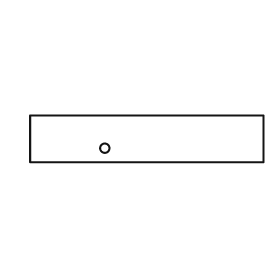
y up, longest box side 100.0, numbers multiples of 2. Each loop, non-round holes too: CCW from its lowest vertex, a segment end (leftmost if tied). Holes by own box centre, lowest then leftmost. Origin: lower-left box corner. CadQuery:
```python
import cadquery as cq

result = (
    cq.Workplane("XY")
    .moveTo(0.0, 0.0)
    .lineTo(100.0, 0.0)
    .lineTo(100.0, 20.0)
    .lineTo(0.0, 20.0)
    .close()
    .moveTo(32.0, 6.0)
    .circle(2.0)
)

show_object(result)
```